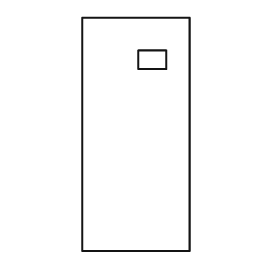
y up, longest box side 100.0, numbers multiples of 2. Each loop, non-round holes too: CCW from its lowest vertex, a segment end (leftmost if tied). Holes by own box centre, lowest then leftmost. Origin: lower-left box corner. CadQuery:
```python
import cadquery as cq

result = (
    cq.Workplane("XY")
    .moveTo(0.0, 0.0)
    .lineTo(46.0, 0.0)
    .lineTo(46.0, 100.0)
    .lineTo(0.0, 100.0)
    .close()
    .moveTo(24.0, 78.0)
    .lineTo(36.0, 78.0)
    .lineTo(36.0, 86.0)
    .lineTo(24.0, 86.0)
    .close()
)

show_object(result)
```